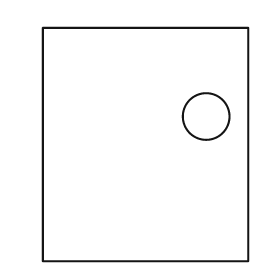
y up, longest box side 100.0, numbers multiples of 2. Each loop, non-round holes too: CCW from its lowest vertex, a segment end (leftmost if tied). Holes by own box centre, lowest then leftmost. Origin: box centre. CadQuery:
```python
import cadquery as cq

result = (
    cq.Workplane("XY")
    .moveTo(-44.0, -50.0)
    .lineTo(44.0, -50.0)
    .lineTo(44.0, 50.0)
    .lineTo(-44.0, 50.0)
    .close()
    .moveTo(26.0, 12.0)
    .circle(10.0)
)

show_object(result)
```